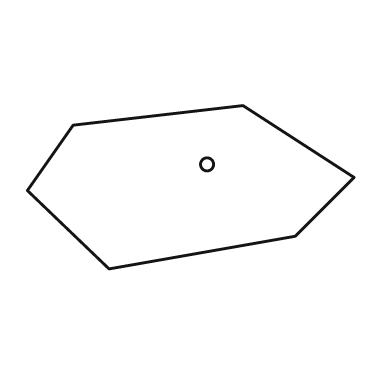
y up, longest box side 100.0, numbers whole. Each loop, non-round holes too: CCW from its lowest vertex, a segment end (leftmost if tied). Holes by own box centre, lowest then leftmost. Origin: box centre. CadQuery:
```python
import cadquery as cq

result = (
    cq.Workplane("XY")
    .moveTo(-25.0, -25.0)
    .lineTo(32.0, -15.0)
    .lineTo(50.0, 3.0)
    .lineTo(16.0, 25.0)
    .lineTo(-36.0, 19.0)
    .lineTo(-50.0, -1.0)
    .close()
    .moveTo(5.0, 7.0)
    .circle(2.0)
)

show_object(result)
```